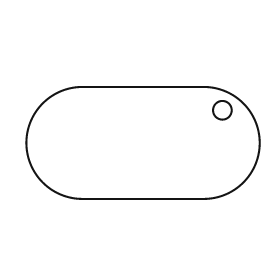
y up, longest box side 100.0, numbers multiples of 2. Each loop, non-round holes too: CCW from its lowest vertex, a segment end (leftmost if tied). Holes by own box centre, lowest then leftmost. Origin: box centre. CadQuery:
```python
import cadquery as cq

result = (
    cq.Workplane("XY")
    .moveTo(-26.0, -24.0)
    .lineTo(26.0, -24.0)
    .threePointArc((50.0, 0.0), (26.0, 24.0))
    .lineTo(-26.0, 24.0)
    .threePointArc((-50.0, 0.0), (-26.0, -24.0))
    .close()
    .moveTo(34.0, 14.0)
    .circle(4.0)
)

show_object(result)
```